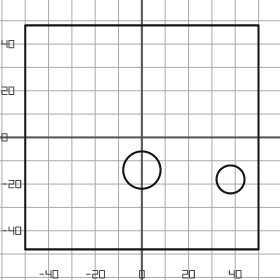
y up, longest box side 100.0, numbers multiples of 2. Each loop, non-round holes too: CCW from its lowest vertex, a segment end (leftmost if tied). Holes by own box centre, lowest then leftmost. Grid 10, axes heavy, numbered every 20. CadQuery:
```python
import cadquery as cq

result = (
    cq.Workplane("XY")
    .moveTo(-50.0, -48.0)
    .lineTo(50.0, -48.0)
    .lineTo(50.0, 48.0)
    .lineTo(-50.0, 48.0)
    .close()
    .moveTo(38.0, -18.0)
    .circle(6.0)
    .moveTo(0.0, -14.0)
    .circle(8.0)
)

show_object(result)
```